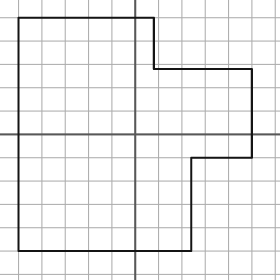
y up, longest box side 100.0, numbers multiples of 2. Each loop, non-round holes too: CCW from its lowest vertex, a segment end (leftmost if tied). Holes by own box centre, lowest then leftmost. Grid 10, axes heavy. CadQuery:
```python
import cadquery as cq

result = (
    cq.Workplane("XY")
    .moveTo(-50.0, -50.0)
    .lineTo(24.0, -50.0)
    .lineTo(24.0, -10.0)
    .lineTo(50.0, -10.0)
    .lineTo(50.0, 28.0)
    .lineTo(8.0, 28.0)
    .lineTo(8.0, 50.0)
    .lineTo(-50.0, 50.0)
    .close()
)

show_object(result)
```